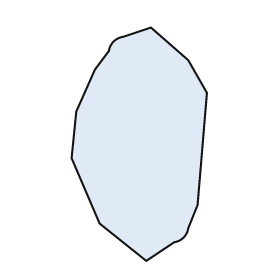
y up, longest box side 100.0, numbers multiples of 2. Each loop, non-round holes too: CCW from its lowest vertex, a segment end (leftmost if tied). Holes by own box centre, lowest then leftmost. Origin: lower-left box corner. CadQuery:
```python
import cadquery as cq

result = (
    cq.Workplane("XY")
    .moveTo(32.0, 0.0)
    .lineTo(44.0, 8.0)
    .threePointArc((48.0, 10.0), (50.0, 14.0))
    .lineTo(54.0, 24.0)
    .lineTo(58.0, 72.0)
    .lineTo(50.0, 86.0)
    .lineTo(34.0, 100.0)
    .lineTo(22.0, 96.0)
    .threePointArc((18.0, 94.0), (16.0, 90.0))
    .lineTo(10.0, 82.0)
    .lineTo(2.0, 64.0)
    .lineTo(0.0, 44.0)
    .lineTo(12.0, 16.0)
    .close()
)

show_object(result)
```